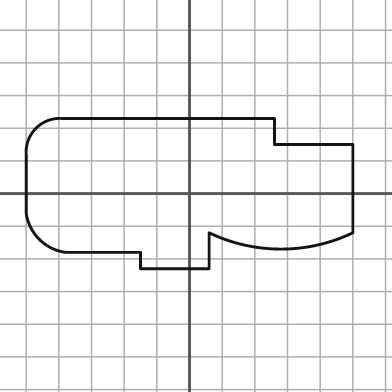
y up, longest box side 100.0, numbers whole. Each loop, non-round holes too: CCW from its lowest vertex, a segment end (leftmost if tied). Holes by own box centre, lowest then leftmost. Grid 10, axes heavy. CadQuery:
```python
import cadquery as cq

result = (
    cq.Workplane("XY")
    .moveTo(-15.0, -23.0)
    .lineTo(6.0, -23.0)
    .lineTo(6.0, -12.0)
    .threePointArc((28.0, -17.0), (50.0, -12.0))
    .lineTo(50.0, 15.0)
    .lineTo(26.0, 15.0)
    .lineTo(26.0, 23.0)
    .lineTo(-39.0, 23.0)
    .threePointArc((-47.0, 20.0), (-50.0, 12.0))
    .lineTo(-50.0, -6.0)
    .threePointArc((-46.0, -14.0), (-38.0, -18.0))
    .lineTo(-15.0, -18.0)
    .close()
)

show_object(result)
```